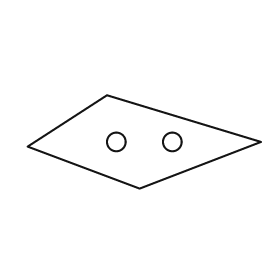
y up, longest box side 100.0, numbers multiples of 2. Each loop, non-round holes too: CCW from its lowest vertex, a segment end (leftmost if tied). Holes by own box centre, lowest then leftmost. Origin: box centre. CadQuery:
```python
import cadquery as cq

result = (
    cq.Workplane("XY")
    .moveTo(-2.0, -20.0)
    .lineTo(50.0, 0.0)
    .lineTo(-16.0, 20.0)
    .lineTo(-50.0, -2.0)
    .close()
    .moveTo(-12.0, 0.0)
    .circle(4.0)
    .moveTo(12.0, 0.0)
    .circle(4.0)
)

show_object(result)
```